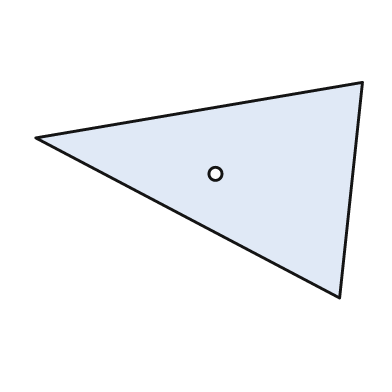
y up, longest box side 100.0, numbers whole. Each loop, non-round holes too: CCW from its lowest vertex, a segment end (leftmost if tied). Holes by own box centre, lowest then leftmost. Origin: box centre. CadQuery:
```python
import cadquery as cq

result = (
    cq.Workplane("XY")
    .moveTo(43.0, -33.0)
    .lineTo(50.0, 33.0)
    .lineTo(-50.0, 16.0)
    .close()
    .moveTo(5.0, 5.0)
    .circle(2.0)
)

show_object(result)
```